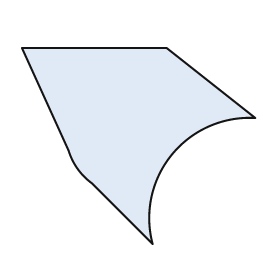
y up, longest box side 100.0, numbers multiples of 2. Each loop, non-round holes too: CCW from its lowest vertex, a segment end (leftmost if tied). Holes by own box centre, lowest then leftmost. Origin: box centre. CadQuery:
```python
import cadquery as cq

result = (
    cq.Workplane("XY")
    .moveTo(6.0, -42.0)
    .threePointArc((14.0, -4.0), (50.0, 12.0))
    .lineTo(12.0, 42.0)
    .lineTo(-50.0, 42.0)
    .lineTo(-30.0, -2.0)
    .threePointArc((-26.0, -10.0), (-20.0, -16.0))
    .close()
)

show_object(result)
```